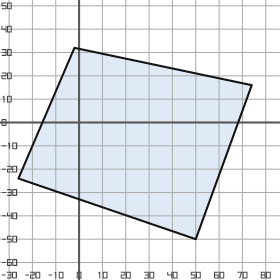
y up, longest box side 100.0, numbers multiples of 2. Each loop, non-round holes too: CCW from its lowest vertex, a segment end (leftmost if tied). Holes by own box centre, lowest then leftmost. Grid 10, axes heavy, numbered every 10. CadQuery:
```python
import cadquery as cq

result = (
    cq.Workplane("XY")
    .moveTo(50.0, -50.0)
    .lineTo(74.0, 16.0)
    .lineTo(-2.0, 32.0)
    .lineTo(-26.0, -24.0)
    .close()
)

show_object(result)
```